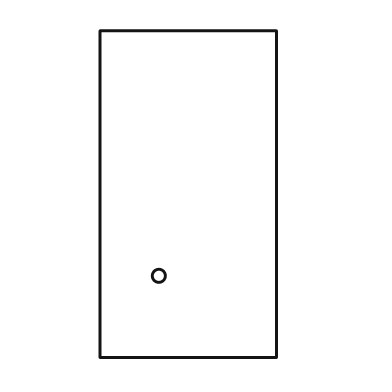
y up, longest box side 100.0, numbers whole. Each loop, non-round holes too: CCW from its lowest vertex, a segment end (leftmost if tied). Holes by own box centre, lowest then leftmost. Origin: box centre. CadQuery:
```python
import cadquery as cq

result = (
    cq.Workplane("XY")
    .moveTo(-27.0, -50.0)
    .lineTo(27.0, -50.0)
    .lineTo(27.0, 50.0)
    .lineTo(-27.0, 50.0)
    .close()
    .moveTo(-9.0, -25.0)
    .circle(2.0)
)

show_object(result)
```